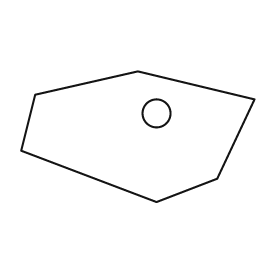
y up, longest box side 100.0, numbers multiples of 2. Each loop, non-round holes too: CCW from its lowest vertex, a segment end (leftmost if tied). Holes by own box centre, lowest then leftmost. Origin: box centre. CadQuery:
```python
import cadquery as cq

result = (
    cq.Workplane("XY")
    .moveTo(8.0, -28.0)
    .lineTo(34.0, -18.0)
    .lineTo(50.0, 16.0)
    .lineTo(0.0, 28.0)
    .lineTo(-44.0, 18.0)
    .lineTo(-50.0, -6.0)
    .close()
    .moveTo(8.0, 10.0)
    .circle(6.0)
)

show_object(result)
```